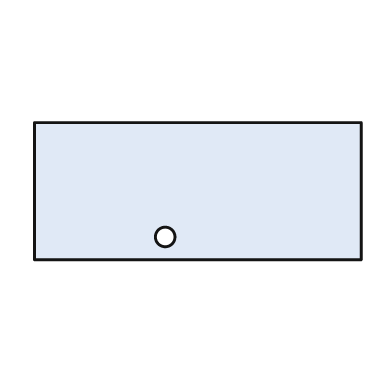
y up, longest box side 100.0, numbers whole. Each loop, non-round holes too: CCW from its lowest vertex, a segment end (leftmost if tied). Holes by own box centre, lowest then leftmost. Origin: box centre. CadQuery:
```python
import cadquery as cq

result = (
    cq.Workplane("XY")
    .moveTo(-50.0, -21.0)
    .lineTo(50.0, -21.0)
    .lineTo(50.0, 21.0)
    .lineTo(-50.0, 21.0)
    .close()
    .moveTo(-10.0, -14.0)
    .circle(3.0)
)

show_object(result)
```